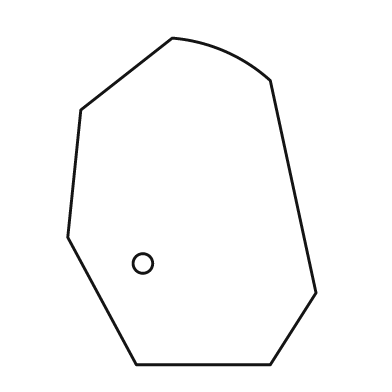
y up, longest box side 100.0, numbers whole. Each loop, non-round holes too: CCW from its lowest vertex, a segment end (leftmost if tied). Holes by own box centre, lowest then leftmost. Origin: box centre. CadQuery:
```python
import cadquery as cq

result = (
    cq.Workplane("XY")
    .moveTo(-17.0, -50.0)
    .lineTo(24.0, -50.0)
    .lineTo(38.0, -28.0)
    .lineTo(24.0, 37.0)
    .threePointArc((10.0, 46.0), (-6.0, 50.0))
    .lineTo(-34.0, 28.0)
    .lineTo(-38.0, -11.0)
    .close()
    .moveTo(-15.0, -19.0)
    .circle(3.0)
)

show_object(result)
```